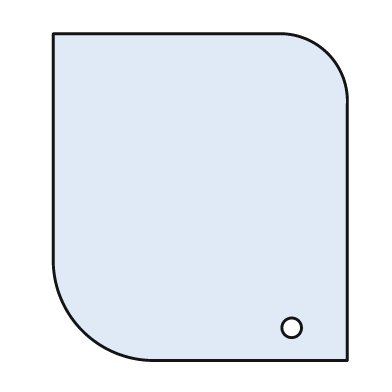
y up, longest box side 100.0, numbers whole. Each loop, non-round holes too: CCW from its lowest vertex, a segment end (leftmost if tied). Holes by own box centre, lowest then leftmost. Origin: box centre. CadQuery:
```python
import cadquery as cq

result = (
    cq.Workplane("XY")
    .moveTo(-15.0, -50.0)
    .lineTo(45.0, -50.0)
    .lineTo(45.0, 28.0)
    .threePointArc((39.0, 44.0), (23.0, 50.0))
    .lineTo(-45.0, 50.0)
    .lineTo(-45.0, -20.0)
    .threePointArc((-36.0, -41.0), (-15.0, -50.0))
    .close()
    .moveTo(28.0, -40.0)
    .circle(3.0)
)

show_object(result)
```